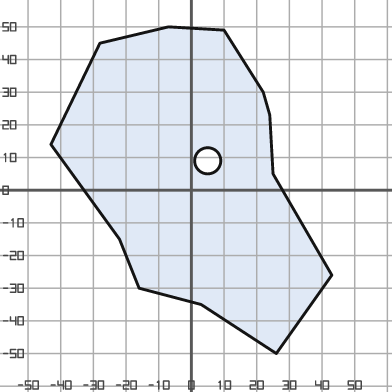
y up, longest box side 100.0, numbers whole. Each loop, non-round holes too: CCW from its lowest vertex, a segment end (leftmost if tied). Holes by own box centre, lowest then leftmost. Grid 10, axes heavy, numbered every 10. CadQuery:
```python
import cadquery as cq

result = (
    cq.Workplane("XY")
    .moveTo(26.0, -50.0)
    .lineTo(43.0, -26.0)
    .lineTo(25.0, 5.0)
    .lineTo(24.0, 23.0)
    .lineTo(22.0, 30.0)
    .lineTo(10.0, 49.0)
    .lineTo(-7.0, 50.0)
    .lineTo(-28.0, 45.0)
    .lineTo(-43.0, 14.0)
    .lineTo(-22.0, -15.0)
    .lineTo(-16.0, -30.0)
    .lineTo(3.0, -35.0)
    .close()
    .moveTo(5.0, 9.0)
    .circle(4.0)
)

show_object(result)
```